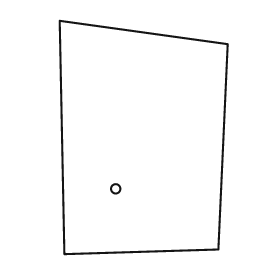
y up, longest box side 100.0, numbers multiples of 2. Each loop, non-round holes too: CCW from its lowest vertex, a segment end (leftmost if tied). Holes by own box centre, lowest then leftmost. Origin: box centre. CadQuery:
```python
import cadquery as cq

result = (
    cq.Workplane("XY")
    .moveTo(-34.0, -50.0)
    .lineTo(32.0, -48.0)
    .lineTo(36.0, 40.0)
    .lineTo(-36.0, 50.0)
    .close()
    .moveTo(-12.0, -22.0)
    .circle(2.0)
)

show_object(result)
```